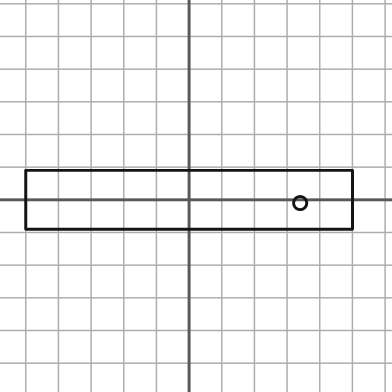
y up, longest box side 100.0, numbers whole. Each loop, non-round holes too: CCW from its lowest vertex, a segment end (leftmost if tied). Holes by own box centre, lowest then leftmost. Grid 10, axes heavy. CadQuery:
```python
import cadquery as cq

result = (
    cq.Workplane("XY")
    .moveTo(-50.0, -9.0)
    .lineTo(50.0, -9.0)
    .lineTo(50.0, 9.0)
    .lineTo(-50.0, 9.0)
    .close()
    .moveTo(34.0, -1.0)
    .circle(2.0)
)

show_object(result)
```